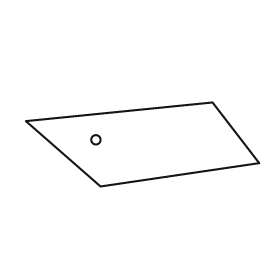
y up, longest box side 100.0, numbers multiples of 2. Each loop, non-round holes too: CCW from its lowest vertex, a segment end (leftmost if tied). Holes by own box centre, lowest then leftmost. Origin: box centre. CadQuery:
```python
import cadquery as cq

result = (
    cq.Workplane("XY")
    .moveTo(-18.0, -18.0)
    .lineTo(50.0, -8.0)
    .lineTo(30.0, 18.0)
    .lineTo(-50.0, 10.0)
    .close()
    .moveTo(-20.0, 2.0)
    .circle(2.0)
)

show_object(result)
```